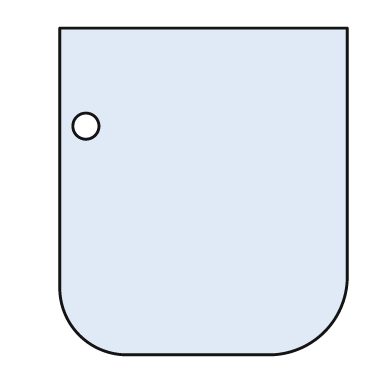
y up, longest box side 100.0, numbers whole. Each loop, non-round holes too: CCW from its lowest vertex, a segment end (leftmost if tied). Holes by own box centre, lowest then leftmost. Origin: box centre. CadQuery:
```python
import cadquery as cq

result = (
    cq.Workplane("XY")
    .moveTo(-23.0, -50.0)
    .lineTo(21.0, -50.0)
    .threePointArc((37.0, -43.0), (44.0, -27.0))
    .lineTo(44.0, 50.0)
    .lineTo(-44.0, 50.0)
    .lineTo(-44.0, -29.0)
    .threePointArc((-38.0, -44.0), (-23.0, -50.0))
    .close()
    .moveTo(-36.0, 20.0)
    .circle(4.0)
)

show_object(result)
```